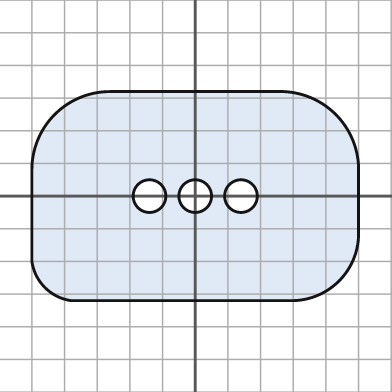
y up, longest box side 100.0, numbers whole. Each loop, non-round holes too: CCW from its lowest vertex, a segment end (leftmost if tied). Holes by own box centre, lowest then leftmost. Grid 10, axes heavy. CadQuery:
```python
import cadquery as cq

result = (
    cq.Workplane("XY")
    .moveTo(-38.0, -32.0)
    .lineTo(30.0, -32.0)
    .threePointArc((44.0, -26.0), (50.0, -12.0))
    .lineTo(50.0, 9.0)
    .threePointArc((43.0, 25.0), (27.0, 32.0))
    .lineTo(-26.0, 32.0)
    .threePointArc((-43.0, 25.0), (-50.0, 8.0))
    .lineTo(-50.0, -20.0)
    .threePointArc((-46.0, -28.0), (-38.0, -32.0))
    .close()
    .moveTo(-14.0, 0.0)
    .circle(5.0)
    .moveTo(0.0, 0.0)
    .circle(5.0)
    .moveTo(14.0, 0.0)
    .circle(5.0)
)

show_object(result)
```